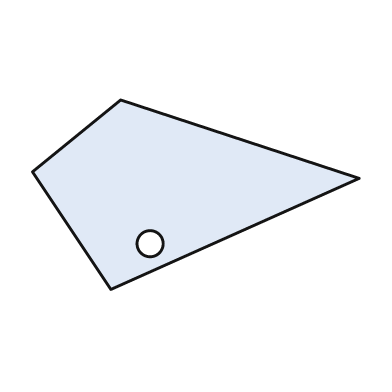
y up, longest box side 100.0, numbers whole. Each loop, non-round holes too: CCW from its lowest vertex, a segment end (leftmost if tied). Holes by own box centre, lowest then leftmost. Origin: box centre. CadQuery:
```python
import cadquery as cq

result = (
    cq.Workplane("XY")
    .moveTo(-26.0, -29.0)
    .lineTo(50.0, 5.0)
    .lineTo(-23.0, 29.0)
    .lineTo(-50.0, 7.0)
    .close()
    .moveTo(-14.0, -15.0)
    .circle(4.0)
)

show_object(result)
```